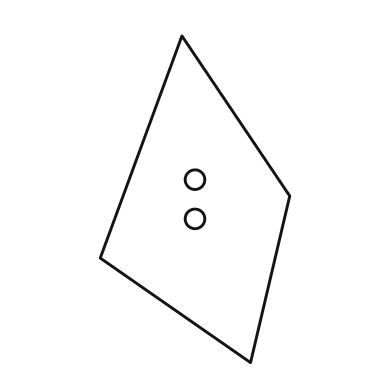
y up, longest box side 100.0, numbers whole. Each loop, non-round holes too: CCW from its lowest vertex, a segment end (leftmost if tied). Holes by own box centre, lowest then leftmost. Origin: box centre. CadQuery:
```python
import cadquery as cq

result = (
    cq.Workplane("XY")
    .moveTo(17.0, -50.0)
    .lineTo(29.0, 1.0)
    .lineTo(-4.0, 50.0)
    .lineTo(-29.0, -18.0)
    .close()
    .moveTo(0.0, -6.0)
    .circle(3.0)
    .moveTo(0.0, 6.0)
    .circle(3.0)
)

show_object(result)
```